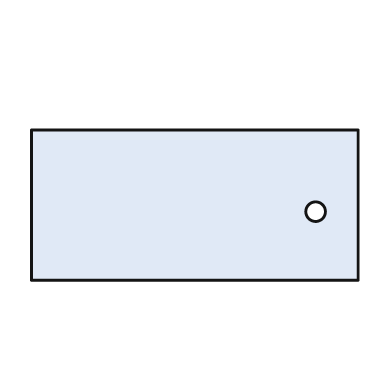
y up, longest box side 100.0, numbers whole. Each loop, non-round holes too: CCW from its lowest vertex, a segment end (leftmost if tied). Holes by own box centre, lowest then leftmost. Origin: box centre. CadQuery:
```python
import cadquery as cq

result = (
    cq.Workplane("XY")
    .moveTo(-50.0, -23.0)
    .lineTo(50.0, -23.0)
    .lineTo(50.0, 23.0)
    .lineTo(-50.0, 23.0)
    .close()
    .moveTo(37.0, -2.0)
    .circle(3.0)
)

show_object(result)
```